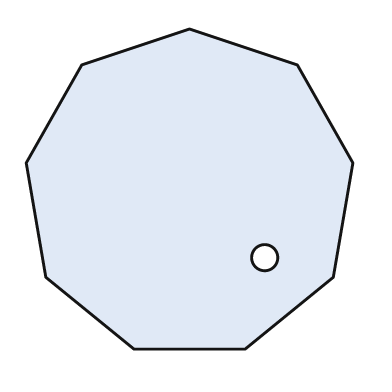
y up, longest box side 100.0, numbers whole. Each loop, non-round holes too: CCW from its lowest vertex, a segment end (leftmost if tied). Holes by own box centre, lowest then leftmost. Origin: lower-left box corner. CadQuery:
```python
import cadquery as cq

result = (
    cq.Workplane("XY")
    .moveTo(33.0, 0.0)
    .lineTo(67.0, 0.0)
    .lineTo(94.0, 22.0)
    .lineTo(100.0, 57.0)
    .lineTo(83.0, 87.0)
    .lineTo(50.0, 98.0)
    .lineTo(17.0, 87.0)
    .lineTo(0.0, 57.0)
    .lineTo(6.0, 22.0)
    .close()
    .moveTo(73.0, 28.0)
    .circle(4.0)
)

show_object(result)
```